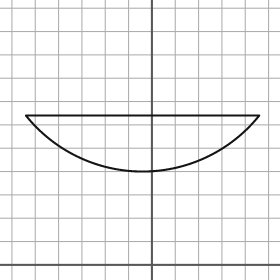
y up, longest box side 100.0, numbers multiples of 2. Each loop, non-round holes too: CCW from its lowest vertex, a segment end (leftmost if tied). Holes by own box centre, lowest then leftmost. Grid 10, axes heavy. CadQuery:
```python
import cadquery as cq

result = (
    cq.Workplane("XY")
    .moveTo(-54.0, 64.0)
    .threePointArc((-4.0, 40.0), (46.0, 64.0))
    .close()
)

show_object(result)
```